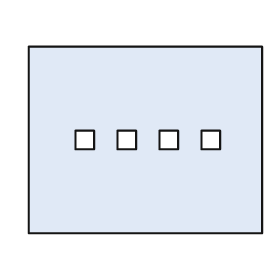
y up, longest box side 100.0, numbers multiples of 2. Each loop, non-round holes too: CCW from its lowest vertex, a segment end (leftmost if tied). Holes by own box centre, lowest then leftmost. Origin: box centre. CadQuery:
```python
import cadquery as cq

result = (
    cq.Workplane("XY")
    .moveTo(-50.0, -40.0)
    .lineTo(50.0, -40.0)
    .lineTo(50.0, 40.0)
    .lineTo(-50.0, 40.0)
    .close()
    .moveTo(-30.0, -4.0)
    .lineTo(-22.0, -4.0)
    .lineTo(-22.0, 4.0)
    .lineTo(-30.0, 4.0)
    .close()
    .moveTo(-12.0, -4.0)
    .lineTo(-4.0, -4.0)
    .lineTo(-4.0, 4.0)
    .lineTo(-12.0, 4.0)
    .close()
    .moveTo(6.0, -4.0)
    .lineTo(14.0, -4.0)
    .lineTo(14.0, 4.0)
    .lineTo(6.0, 4.0)
    .close()
    .moveTo(24.0, -4.0)
    .lineTo(32.0, -4.0)
    .lineTo(32.0, 4.0)
    .lineTo(24.0, 4.0)
    .close()
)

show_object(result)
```